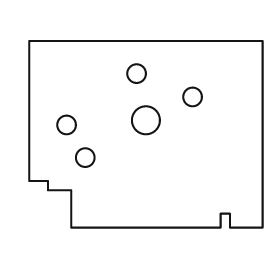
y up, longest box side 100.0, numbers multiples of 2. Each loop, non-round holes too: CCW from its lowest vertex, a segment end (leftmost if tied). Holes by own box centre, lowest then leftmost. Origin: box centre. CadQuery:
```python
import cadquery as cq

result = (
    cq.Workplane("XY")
    .moveTo(-32.0, -40.0)
    .lineTo(32.0, -40.0)
    .lineTo(32.0, -34.0)
    .lineTo(36.0, -34.0)
    .lineTo(36.0, -40.0)
    .lineTo(50.0, -40.0)
    .lineTo(50.0, 40.0)
    .lineTo(-50.0, 40.0)
    .lineTo(-50.0, -20.0)
    .lineTo(-42.0, -20.0)
    .lineTo(-42.0, -24.0)
    .lineTo(-32.0, -24.0)
    .close()
    .moveTo(-26.0, -10.0)
    .circle(4.0)
    .moveTo(-34.0, 4.0)
    .circle(4.0)
    .moveTo(0.0, 6.0)
    .circle(6.0)
    .moveTo(20.0, 16.0)
    .circle(4.0)
    .moveTo(-4.0, 26.0)
    .circle(4.0)
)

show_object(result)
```